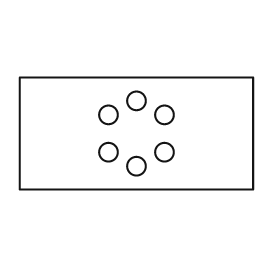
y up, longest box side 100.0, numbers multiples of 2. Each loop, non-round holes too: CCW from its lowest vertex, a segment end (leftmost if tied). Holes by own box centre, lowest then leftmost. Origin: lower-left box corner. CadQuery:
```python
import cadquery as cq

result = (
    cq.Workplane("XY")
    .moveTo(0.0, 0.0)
    .lineTo(100.0, 0.0)
    .lineTo(100.0, 48.0)
    .lineTo(0.0, 48.0)
    .close()
    .moveTo(50.0, 10.0)
    .circle(4.0)
    .moveTo(38.0, 16.0)
    .circle(4.0)
    .moveTo(62.0, 16.0)
    .circle(4.0)
    .moveTo(38.0, 32.0)
    .circle(4.0)
    .moveTo(62.0, 32.0)
    .circle(4.0)
    .moveTo(50.0, 38.0)
    .circle(4.0)
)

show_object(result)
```